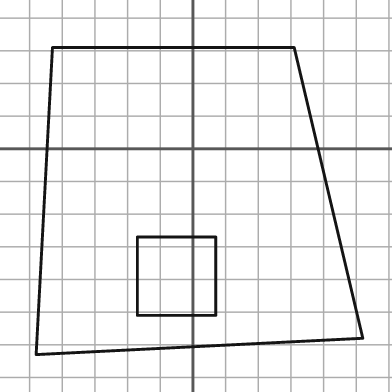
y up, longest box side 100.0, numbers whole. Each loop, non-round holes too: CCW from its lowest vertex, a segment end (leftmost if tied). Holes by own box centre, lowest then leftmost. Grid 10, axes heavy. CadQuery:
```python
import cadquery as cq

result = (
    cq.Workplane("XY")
    .moveTo(-48.0, -63.0)
    .lineTo(52.0, -58.0)
    .lineTo(31.0, 31.0)
    .lineTo(-43.0, 31.0)
    .close()
    .moveTo(-17.0, -51.0)
    .lineTo(7.0, -51.0)
    .lineTo(7.0, -27.0)
    .lineTo(-17.0, -27.0)
    .close()
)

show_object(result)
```